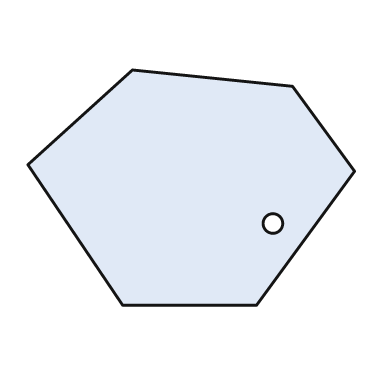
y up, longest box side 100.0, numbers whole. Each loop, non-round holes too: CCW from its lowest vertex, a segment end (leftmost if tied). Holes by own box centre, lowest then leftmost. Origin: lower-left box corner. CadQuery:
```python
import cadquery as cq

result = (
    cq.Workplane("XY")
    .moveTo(29.0, 0.0)
    .lineTo(70.0, 0.0)
    .lineTo(100.0, 41.0)
    .lineTo(81.0, 67.0)
    .lineTo(32.0, 72.0)
    .lineTo(0.0, 43.0)
    .close()
    .moveTo(75.0, 25.0)
    .circle(3.0)
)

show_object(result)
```